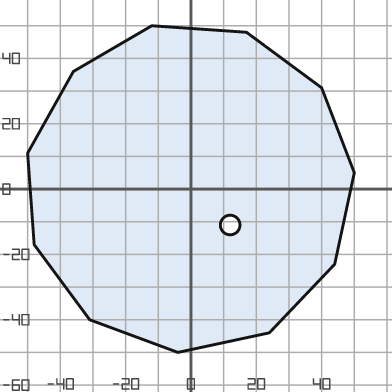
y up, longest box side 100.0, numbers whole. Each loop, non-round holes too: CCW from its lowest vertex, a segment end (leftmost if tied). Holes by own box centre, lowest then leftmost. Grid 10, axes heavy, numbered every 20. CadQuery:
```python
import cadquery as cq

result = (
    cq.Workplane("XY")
    .moveTo(-4.0, -50.0)
    .lineTo(24.0, -44.0)
    .lineTo(44.0, -23.0)
    .lineTo(50.0, 5.0)
    .lineTo(40.0, 31.0)
    .lineTo(17.0, 48.0)
    .lineTo(-12.0, 50.0)
    .lineTo(-36.0, 36.0)
    .lineTo(-50.0, 11.0)
    .lineTo(-48.0, -17.0)
    .lineTo(-31.0, -40.0)
    .close()
    .moveTo(12.0, -11.0)
    .circle(3.0)
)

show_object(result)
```